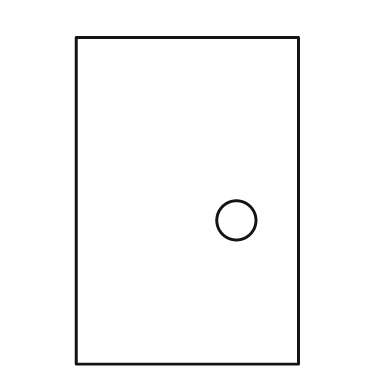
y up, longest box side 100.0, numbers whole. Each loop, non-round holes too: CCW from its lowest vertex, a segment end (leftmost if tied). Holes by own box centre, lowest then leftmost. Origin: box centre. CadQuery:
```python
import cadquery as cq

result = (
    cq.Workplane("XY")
    .moveTo(-34.0, -50.0)
    .lineTo(34.0, -50.0)
    .lineTo(34.0, 50.0)
    .lineTo(-34.0, 50.0)
    .close()
    .moveTo(15.0, -6.0)
    .circle(6.0)
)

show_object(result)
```